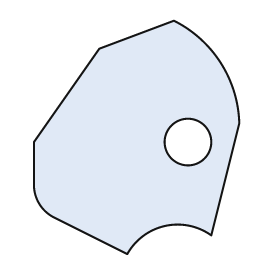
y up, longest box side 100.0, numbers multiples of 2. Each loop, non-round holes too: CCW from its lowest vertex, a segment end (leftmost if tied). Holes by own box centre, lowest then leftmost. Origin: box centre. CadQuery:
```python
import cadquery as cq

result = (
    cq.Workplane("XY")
    .moveTo(-4.0, -50.0)
    .threePointArc((12.0, -38.0), (32.0, -42.0))
    .lineTo(44.0, 6.0)
    .threePointArc((36.0, 32.0), (16.0, 50.0))
    .lineTo(-16.0, 38.0)
    .lineTo(-44.0, -2.0)
    .lineTo(-44.0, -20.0)
    .threePointArc((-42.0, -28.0), (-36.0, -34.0))
    .close()
    .moveTo(22.0, -2.0)
    .circle(10.0)
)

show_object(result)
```